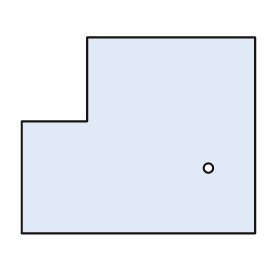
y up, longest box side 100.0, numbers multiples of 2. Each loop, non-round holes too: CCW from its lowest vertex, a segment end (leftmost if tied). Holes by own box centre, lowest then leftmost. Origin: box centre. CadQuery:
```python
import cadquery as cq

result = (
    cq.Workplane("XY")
    .moveTo(-50.0, -42.0)
    .lineTo(50.0, -42.0)
    .lineTo(50.0, 42.0)
    .lineTo(-22.0, 42.0)
    .lineTo(-22.0, 6.0)
    .lineTo(-50.0, 6.0)
    .close()
    .moveTo(30.0, -14.0)
    .circle(2.0)
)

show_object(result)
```